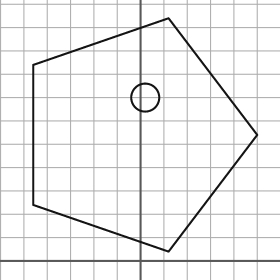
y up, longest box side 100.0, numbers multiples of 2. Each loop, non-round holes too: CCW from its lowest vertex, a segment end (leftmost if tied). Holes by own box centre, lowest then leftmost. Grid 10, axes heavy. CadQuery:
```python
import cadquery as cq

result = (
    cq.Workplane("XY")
    .moveTo(12.0, 4.0)
    .lineTo(50.0, 54.0)
    .lineTo(12.0, 104.0)
    .lineTo(-46.0, 84.0)
    .lineTo(-46.0, 24.0)
    .close()
    .moveTo(2.0, 70.0)
    .circle(6.0)
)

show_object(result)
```